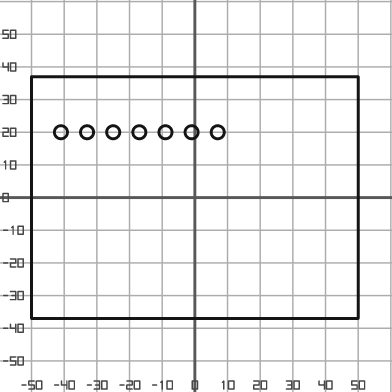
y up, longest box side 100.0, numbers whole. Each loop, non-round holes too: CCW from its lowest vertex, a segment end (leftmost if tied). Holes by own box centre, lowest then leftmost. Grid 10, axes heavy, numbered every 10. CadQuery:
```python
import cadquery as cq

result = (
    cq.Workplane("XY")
    .moveTo(-50.0, -37.0)
    .lineTo(50.0, -37.0)
    .lineTo(50.0, 37.0)
    .lineTo(-50.0, 37.0)
    .close()
    .moveTo(-41.0, 20.0)
    .circle(2.0)
    .moveTo(-33.0, 20.0)
    .circle(2.0)
    .moveTo(-25.0, 20.0)
    .circle(2.0)
    .moveTo(-17.0, 20.0)
    .circle(2.0)
    .moveTo(-9.0, 20.0)
    .circle(2.0)
    .moveTo(-1.0, 20.0)
    .circle(2.0)
    .moveTo(7.0, 20.0)
    .circle(2.0)
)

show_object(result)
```